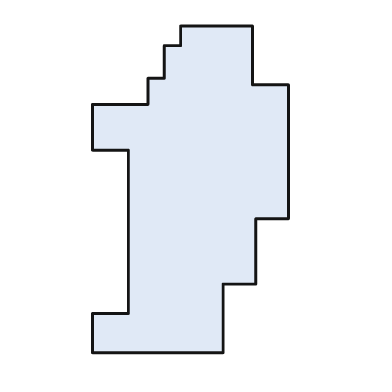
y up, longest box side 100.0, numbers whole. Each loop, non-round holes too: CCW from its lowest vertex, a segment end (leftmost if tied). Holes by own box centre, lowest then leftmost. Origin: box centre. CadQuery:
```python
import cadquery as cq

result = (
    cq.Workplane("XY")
    .moveTo(-30.0, -50.0)
    .lineTo(10.0, -50.0)
    .lineTo(10.0, -29.0)
    .lineTo(20.0, -29.0)
    .lineTo(20.0, -9.0)
    .lineTo(30.0, -9.0)
    .lineTo(30.0, 32.0)
    .lineTo(19.0, 32.0)
    .lineTo(19.0, 50.0)
    .lineTo(-3.0, 50.0)
    .lineTo(-3.0, 44.0)
    .lineTo(-8.0, 44.0)
    .lineTo(-8.0, 34.0)
    .lineTo(-13.0, 34.0)
    .lineTo(-13.0, 26.0)
    .lineTo(-30.0, 26.0)
    .lineTo(-30.0, 12.0)
    .lineTo(-19.0, 12.0)
    .lineTo(-19.0, -38.0)
    .lineTo(-30.0, -38.0)
    .close()
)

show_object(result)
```